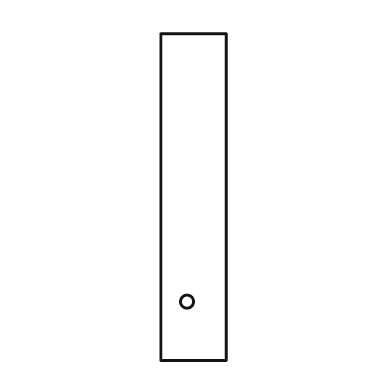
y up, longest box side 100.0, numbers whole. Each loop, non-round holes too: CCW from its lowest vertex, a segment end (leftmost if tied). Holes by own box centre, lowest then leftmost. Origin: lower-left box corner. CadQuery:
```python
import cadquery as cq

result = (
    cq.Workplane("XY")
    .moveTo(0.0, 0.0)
    .lineTo(20.0, 0.0)
    .lineTo(20.0, 100.0)
    .lineTo(0.0, 100.0)
    .close()
    .moveTo(8.0, 18.0)
    .circle(2.0)
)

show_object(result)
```